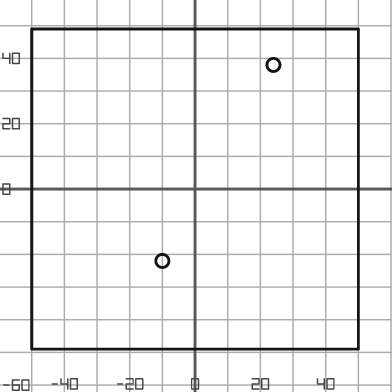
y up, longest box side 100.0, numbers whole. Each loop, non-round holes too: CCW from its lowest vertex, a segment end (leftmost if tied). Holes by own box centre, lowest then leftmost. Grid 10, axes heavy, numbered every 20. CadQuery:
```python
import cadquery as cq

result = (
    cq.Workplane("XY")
    .moveTo(-50.0, -49.0)
    .lineTo(50.0, -49.0)
    .lineTo(50.0, 49.0)
    .lineTo(-50.0, 49.0)
    .close()
    .moveTo(-10.0, -22.0)
    .circle(2.0)
    .moveTo(24.0, 38.0)
    .circle(2.0)
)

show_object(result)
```